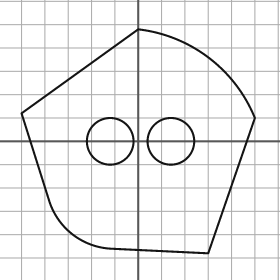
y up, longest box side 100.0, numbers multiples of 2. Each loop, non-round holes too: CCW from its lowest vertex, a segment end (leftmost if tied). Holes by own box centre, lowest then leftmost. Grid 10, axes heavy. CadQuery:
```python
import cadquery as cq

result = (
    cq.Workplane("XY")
    .moveTo(30.0, -48.0)
    .lineTo(50.0, 10.0)
    .threePointArc((30.0, 36.0), (0.0, 48.0))
    .lineTo(-50.0, 12.0)
    .lineTo(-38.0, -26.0)
    .threePointArc((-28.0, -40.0), (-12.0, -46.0))
    .close()
    .moveTo(-12.0, 0.0)
    .circle(10.0)
    .moveTo(14.0, 0.0)
    .circle(10.0)
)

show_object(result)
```